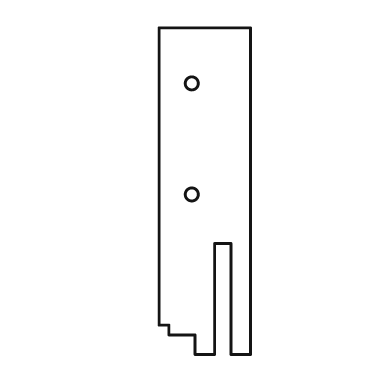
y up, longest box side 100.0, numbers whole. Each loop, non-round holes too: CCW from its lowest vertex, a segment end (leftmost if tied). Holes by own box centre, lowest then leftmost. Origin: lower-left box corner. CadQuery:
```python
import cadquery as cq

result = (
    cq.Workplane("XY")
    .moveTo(11.0, 0.0)
    .lineTo(17.0, 0.0)
    .lineTo(17.0, 34.0)
    .lineTo(22.0, 34.0)
    .lineTo(22.0, 0.0)
    .lineTo(28.0, 0.0)
    .lineTo(28.0, 100.0)
    .lineTo(0.0, 100.0)
    .lineTo(0.0, 9.0)
    .lineTo(3.0, 9.0)
    .lineTo(3.0, 6.0)
    .lineTo(11.0, 6.0)
    .close()
    .moveTo(10.0, 49.0)
    .circle(2.0)
    .moveTo(10.0, 83.0)
    .circle(2.0)
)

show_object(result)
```